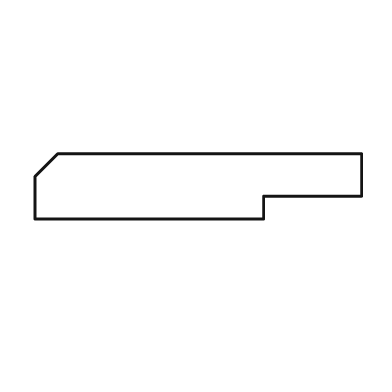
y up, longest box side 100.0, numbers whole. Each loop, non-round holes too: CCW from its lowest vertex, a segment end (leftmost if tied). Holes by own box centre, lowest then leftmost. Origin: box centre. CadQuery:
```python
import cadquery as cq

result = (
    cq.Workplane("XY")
    .moveTo(-50.0, -10.0)
    .lineTo(20.0, -10.0)
    .lineTo(20.0, -3.0)
    .lineTo(50.0, -3.0)
    .lineTo(50.0, 10.0)
    .lineTo(-43.0, 10.0)
    .lineTo(-50.0, 3.0)
    .close()
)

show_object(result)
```